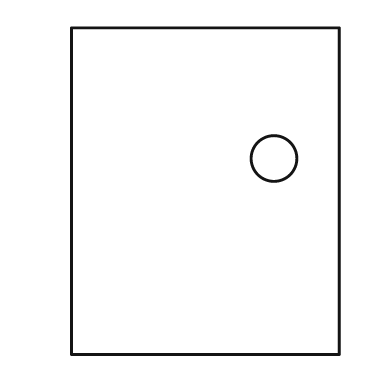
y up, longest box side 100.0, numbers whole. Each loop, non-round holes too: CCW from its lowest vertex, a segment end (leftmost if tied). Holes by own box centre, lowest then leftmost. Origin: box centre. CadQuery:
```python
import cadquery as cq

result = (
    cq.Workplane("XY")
    .moveTo(-41.0, -50.0)
    .lineTo(41.0, -50.0)
    .lineTo(41.0, 50.0)
    .lineTo(-41.0, 50.0)
    .close()
    .moveTo(21.0, 10.0)
    .circle(7.0)
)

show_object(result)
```